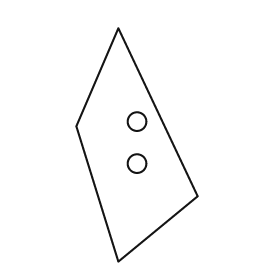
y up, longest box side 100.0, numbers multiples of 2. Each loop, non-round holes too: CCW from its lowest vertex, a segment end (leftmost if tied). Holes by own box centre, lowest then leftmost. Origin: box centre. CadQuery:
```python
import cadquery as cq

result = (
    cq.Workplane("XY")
    .moveTo(-8.0, -50.0)
    .lineTo(26.0, -22.0)
    .lineTo(-8.0, 50.0)
    .lineTo(-26.0, 8.0)
    .close()
    .moveTo(0.0, -8.0)
    .circle(4.0)
    .moveTo(0.0, 10.0)
    .circle(4.0)
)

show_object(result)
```